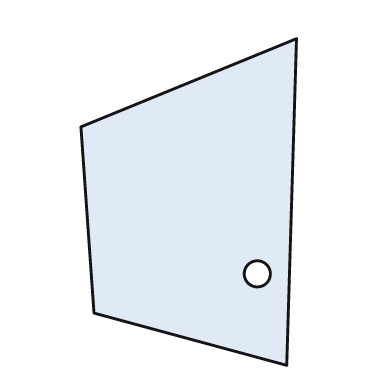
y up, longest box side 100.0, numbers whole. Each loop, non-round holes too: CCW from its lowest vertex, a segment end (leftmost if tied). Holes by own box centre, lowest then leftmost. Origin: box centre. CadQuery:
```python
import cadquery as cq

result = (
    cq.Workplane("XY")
    .moveTo(30.0, -50.0)
    .lineTo(33.0, 50.0)
    .lineTo(-33.0, 23.0)
    .lineTo(-29.0, -34.0)
    .close()
    .moveTo(21.0, -22.0)
    .circle(4.0)
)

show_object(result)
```